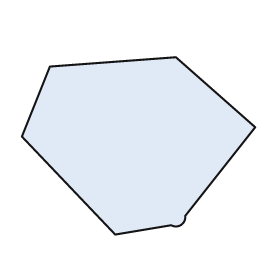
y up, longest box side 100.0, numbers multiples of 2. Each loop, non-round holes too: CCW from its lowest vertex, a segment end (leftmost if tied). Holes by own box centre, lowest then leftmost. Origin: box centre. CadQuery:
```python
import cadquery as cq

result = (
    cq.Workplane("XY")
    .moveTo(-10.0, -38.0)
    .lineTo(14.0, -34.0)
    .threePointArc((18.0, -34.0), (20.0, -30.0))
    .lineTo(50.0, 8.0)
    .lineTo(16.0, 38.0)
    .lineTo(-38.0, 34.0)
    .lineTo(-50.0, 4.0)
    .close()
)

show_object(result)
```